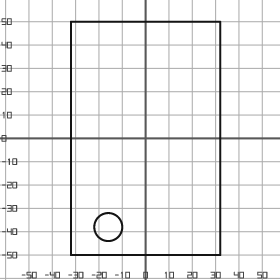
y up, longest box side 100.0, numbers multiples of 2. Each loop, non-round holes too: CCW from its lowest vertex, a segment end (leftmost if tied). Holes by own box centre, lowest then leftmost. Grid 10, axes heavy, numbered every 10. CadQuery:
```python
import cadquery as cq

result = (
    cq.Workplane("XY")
    .moveTo(-32.0, -50.0)
    .lineTo(32.0, -50.0)
    .lineTo(32.0, 50.0)
    .lineTo(-32.0, 50.0)
    .close()
    .moveTo(-16.0, -38.0)
    .circle(6.0)
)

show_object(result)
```